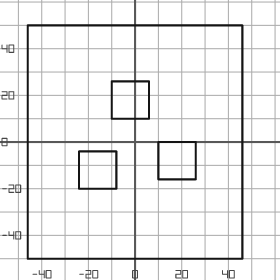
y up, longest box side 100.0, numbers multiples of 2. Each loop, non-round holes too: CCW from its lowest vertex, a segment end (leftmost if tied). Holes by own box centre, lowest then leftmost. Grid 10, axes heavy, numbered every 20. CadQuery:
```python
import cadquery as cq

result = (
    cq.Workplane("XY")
    .moveTo(-46.0, -50.0)
    .lineTo(46.0, -50.0)
    .lineTo(46.0, 50.0)
    .lineTo(-46.0, 50.0)
    .close()
    .moveTo(-24.0, -20.0)
    .lineTo(-8.0, -20.0)
    .lineTo(-8.0, -4.0)
    .lineTo(-24.0, -4.0)
    .close()
    .moveTo(10.0, -16.0)
    .lineTo(26.0, -16.0)
    .lineTo(26.0, 0.0)
    .lineTo(10.0, 0.0)
    .close()
    .moveTo(-10.0, 10.0)
    .lineTo(6.0, 10.0)
    .lineTo(6.0, 26.0)
    .lineTo(-10.0, 26.0)
    .close()
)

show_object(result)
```